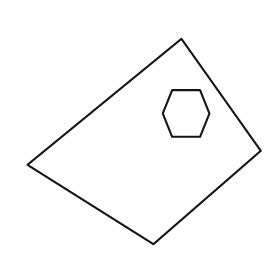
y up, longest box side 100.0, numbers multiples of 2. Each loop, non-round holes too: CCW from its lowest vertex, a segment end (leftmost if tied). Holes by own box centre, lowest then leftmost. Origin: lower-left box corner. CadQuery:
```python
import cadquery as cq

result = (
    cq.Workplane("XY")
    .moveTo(54.0, 0.0)
    .lineTo(100.0, 40.0)
    .lineTo(66.0, 88.0)
    .lineTo(0.0, 34.0)
    .close()
    .moveTo(62.0, 46.0)
    .lineTo(74.0, 46.0)
    .lineTo(78.0, 56.0)
    .lineTo(74.0, 66.0)
    .lineTo(62.0, 66.0)
    .lineTo(58.0, 56.0)
    .close()
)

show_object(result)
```